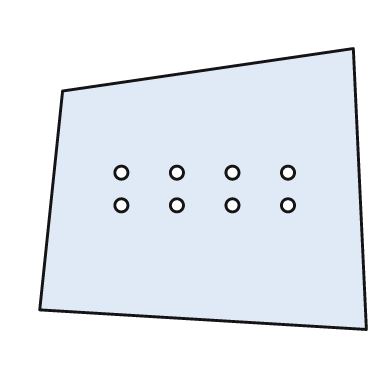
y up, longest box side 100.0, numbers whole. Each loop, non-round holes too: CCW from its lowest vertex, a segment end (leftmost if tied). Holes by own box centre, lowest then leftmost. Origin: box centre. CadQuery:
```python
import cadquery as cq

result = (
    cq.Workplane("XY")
    .moveTo(50.0, -43.0)
    .lineTo(46.0, 43.0)
    .lineTo(-43.0, 30.0)
    .lineTo(-50.0, -37.0)
    .close()
    .moveTo(-25.0, -5.0)
    .circle(2.0)
    .moveTo(-8.0, -5.0)
    .circle(2.0)
    .moveTo(9.0, -5.0)
    .circle(2.0)
    .moveTo(26.0, -5.0)
    .circle(2.0)
    .moveTo(-25.0, 5.0)
    .circle(2.0)
    .moveTo(-8.0, 5.0)
    .circle(2.0)
    .moveTo(9.0, 5.0)
    .circle(2.0)
    .moveTo(26.0, 5.0)
    .circle(2.0)
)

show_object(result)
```